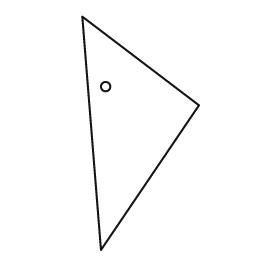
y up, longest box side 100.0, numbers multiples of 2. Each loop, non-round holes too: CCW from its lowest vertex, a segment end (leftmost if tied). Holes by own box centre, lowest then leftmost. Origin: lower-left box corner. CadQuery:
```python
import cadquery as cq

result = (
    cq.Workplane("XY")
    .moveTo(8.0, 0.0)
    .lineTo(50.0, 62.0)
    .lineTo(0.0, 100.0)
    .close()
    .moveTo(10.0, 70.0)
    .circle(2.0)
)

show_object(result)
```